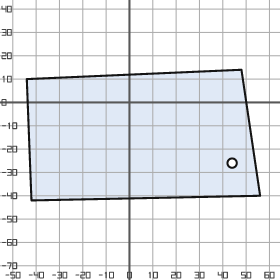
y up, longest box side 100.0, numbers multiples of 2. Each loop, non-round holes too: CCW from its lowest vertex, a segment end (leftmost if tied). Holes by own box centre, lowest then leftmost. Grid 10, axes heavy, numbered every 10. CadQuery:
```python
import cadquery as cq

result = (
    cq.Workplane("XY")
    .moveTo(-42.0, -42.0)
    .lineTo(56.0, -40.0)
    .lineTo(48.0, 14.0)
    .lineTo(-44.0, 10.0)
    .close()
    .moveTo(44.0, -26.0)
    .circle(2.0)
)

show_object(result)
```